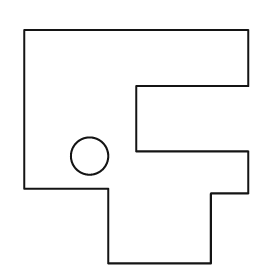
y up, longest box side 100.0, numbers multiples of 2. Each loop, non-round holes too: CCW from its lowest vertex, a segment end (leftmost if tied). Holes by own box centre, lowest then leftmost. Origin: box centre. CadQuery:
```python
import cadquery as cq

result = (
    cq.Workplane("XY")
    .moveTo(-12.0, -50.0)
    .lineTo(32.0, -50.0)
    .lineTo(32.0, -20.0)
    .lineTo(48.0, -20.0)
    .lineTo(48.0, -2.0)
    .lineTo(0.0, -2.0)
    .lineTo(0.0, 26.0)
    .lineTo(48.0, 26.0)
    .lineTo(48.0, 50.0)
    .lineTo(-48.0, 50.0)
    .lineTo(-48.0, -18.0)
    .lineTo(-12.0, -18.0)
    .close()
    .moveTo(-20.0, -4.0)
    .circle(8.0)
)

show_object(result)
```